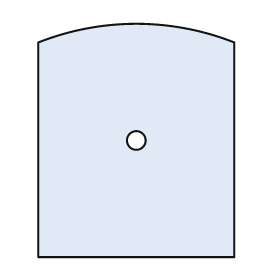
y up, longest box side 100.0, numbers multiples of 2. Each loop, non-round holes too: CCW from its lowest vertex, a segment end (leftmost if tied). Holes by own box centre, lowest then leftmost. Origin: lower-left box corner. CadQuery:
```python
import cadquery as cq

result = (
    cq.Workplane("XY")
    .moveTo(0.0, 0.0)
    .lineTo(84.0, 0.0)
    .lineTo(84.0, 92.0)
    .threePointArc((42.0, 100.0), (0.0, 92.0))
    .close()
    .moveTo(42.0, 50.0)
    .circle(4.0)
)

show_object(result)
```